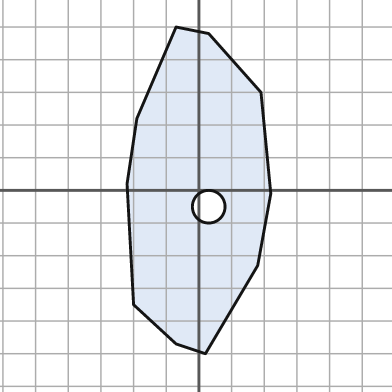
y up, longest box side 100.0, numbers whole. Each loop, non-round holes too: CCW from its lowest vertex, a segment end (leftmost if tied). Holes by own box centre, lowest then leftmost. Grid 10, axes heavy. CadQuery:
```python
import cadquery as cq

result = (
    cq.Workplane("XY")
    .moveTo(2.0, -50.0)
    .lineTo(18.0, -23.0)
    .lineTo(22.0, -1.0)
    .lineTo(19.0, 30.0)
    .lineTo(3.0, 48.0)
    .lineTo(-7.0, 50.0)
    .lineTo(-19.0, 22.0)
    .lineTo(-22.0, 2.0)
    .lineTo(-20.0, -35.0)
    .lineTo(-7.0, -47.0)
    .close()
    .moveTo(3.0, -5.0)
    .circle(5.0)
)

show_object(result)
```